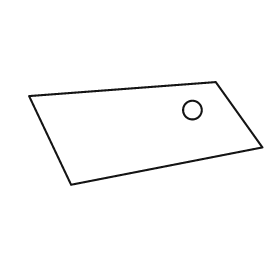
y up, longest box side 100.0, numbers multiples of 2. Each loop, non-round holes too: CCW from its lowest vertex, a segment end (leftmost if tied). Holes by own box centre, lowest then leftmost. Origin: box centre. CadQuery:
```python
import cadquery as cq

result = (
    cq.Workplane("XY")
    .moveTo(-32.0, -22.0)
    .lineTo(50.0, -6.0)
    .lineTo(30.0, 22.0)
    .lineTo(-50.0, 16.0)
    .close()
    .moveTo(20.0, 10.0)
    .circle(4.0)
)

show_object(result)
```